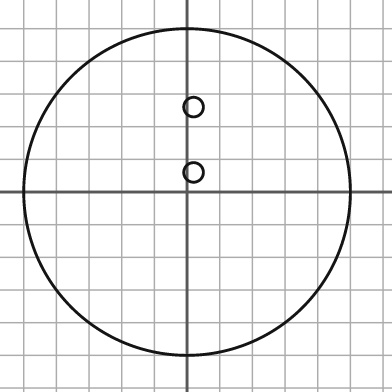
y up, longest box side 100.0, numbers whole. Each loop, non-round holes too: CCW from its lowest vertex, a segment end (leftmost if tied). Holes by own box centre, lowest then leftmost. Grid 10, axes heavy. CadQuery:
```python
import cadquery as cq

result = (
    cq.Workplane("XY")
    .moveTo(0.0, 0.0)
    .circle(50.0)
    .moveTo(2.0, 6.0)
    .circle(3.0)
    .moveTo(2.0, 26.0)
    .circle(3.0)
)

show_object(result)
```